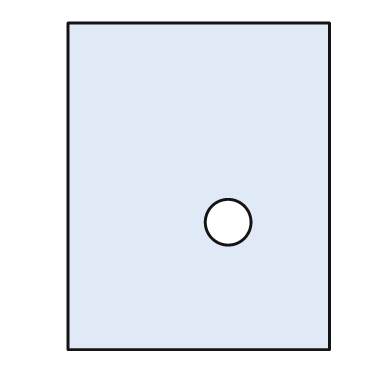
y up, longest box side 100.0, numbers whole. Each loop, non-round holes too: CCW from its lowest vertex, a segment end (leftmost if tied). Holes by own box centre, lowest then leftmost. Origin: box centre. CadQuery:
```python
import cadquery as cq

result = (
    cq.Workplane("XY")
    .moveTo(-40.0, -50.0)
    .lineTo(40.0, -50.0)
    .lineTo(40.0, 50.0)
    .lineTo(-40.0, 50.0)
    .close()
    .moveTo(9.0, -11.0)
    .circle(7.0)
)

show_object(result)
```